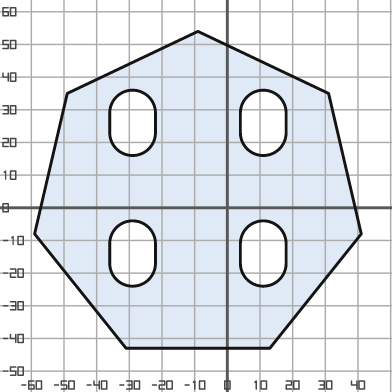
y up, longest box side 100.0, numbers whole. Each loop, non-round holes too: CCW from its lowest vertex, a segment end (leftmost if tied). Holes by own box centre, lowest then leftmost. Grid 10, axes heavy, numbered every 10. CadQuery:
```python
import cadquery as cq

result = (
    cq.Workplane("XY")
    .moveTo(-31.0, -43.0)
    .lineTo(13.0, -43.0)
    .lineTo(41.0, -8.0)
    .lineTo(31.0, 35.0)
    .lineTo(-9.0, 54.0)
    .lineTo(-49.0, 35.0)
    .lineTo(-59.0, -8.0)
    .close()
    .moveTo(-36.0, -17.0)
    .threePointArc((-29.0, -24.0), (-22.0, -17.0))
    .lineTo(-22.0, -11.0)
    .threePointArc((-29.0, -4.0), (-36.0, -11.0))
    .close()
    .moveTo(4.0, -17.0)
    .threePointArc((11.0, -24.0), (18.0, -17.0))
    .lineTo(18.0, -11.0)
    .threePointArc((11.0, -4.0), (4.0, -11.0))
    .close()
    .moveTo(-36.0, 23.0)
    .threePointArc((-29.0, 16.0), (-22.0, 23.0))
    .lineTo(-22.0, 29.0)
    .threePointArc((-29.0, 36.0), (-36.0, 29.0))
    .close()
    .moveTo(4.0, 23.0)
    .threePointArc((11.0, 16.0), (18.0, 23.0))
    .lineTo(18.0, 29.0)
    .threePointArc((11.0, 36.0), (4.0, 29.0))
    .close()
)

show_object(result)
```